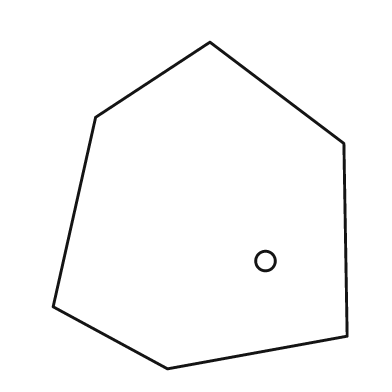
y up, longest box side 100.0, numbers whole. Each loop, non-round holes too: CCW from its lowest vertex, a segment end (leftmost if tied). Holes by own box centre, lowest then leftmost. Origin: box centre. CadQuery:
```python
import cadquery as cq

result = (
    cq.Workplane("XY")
    .moveTo(-10.0, -50.0)
    .lineTo(45.0, -40.0)
    .lineTo(44.0, 19.0)
    .lineTo(3.0, 50.0)
    .lineTo(-32.0, 27.0)
    .lineTo(-45.0, -31.0)
    .close()
    .moveTo(20.0, -17.0)
    .circle(3.0)
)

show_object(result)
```